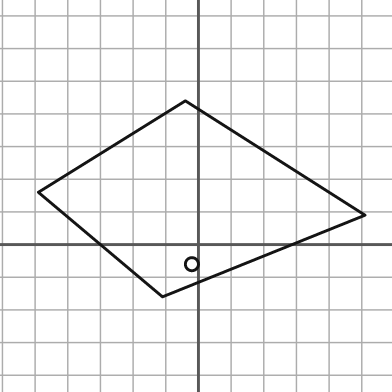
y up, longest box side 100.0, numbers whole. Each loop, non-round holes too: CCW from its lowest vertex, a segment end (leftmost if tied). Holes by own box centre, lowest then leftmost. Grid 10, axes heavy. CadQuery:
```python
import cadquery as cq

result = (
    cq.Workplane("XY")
    .moveTo(-11.0, -16.0)
    .lineTo(51.0, 9.0)
    .lineTo(-4.0, 44.0)
    .lineTo(-49.0, 16.0)
    .close()
    .moveTo(-2.0, -6.0)
    .circle(2.0)
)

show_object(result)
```